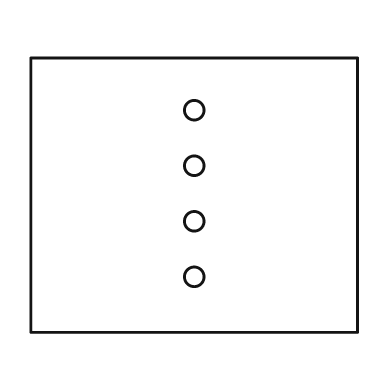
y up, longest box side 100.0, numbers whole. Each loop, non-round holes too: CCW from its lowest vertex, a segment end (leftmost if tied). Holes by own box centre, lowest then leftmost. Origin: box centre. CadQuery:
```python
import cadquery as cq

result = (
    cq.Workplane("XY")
    .moveTo(-50.0, -42.0)
    .lineTo(50.0, -42.0)
    .lineTo(50.0, 42.0)
    .lineTo(-50.0, 42.0)
    .close()
    .moveTo(0.0, -25.0)
    .circle(3.0)
    .moveTo(0.0, -8.0)
    .circle(3.0)
    .moveTo(0.0, 9.0)
    .circle(3.0)
    .moveTo(0.0, 26.0)
    .circle(3.0)
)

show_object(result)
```